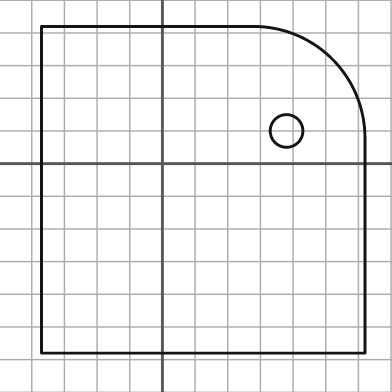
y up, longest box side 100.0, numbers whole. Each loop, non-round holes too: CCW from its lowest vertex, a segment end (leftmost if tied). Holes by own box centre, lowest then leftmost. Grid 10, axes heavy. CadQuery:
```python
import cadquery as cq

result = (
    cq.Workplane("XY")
    .moveTo(-37.0, -58.0)
    .lineTo(62.0, -58.0)
    .lineTo(62.0, 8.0)
    .threePointArc((52.0, 32.0), (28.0, 42.0))
    .lineTo(-37.0, 42.0)
    .close()
    .moveTo(38.0, 10.0)
    .circle(5.0)
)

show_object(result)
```